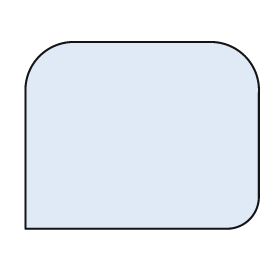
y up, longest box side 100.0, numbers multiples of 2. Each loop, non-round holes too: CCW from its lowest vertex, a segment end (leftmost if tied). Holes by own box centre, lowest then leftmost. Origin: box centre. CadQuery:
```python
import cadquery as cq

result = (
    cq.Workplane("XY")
    .moveTo(-50.0, -40.0)
    .lineTo(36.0, -40.0)
    .threePointArc((46.0, -36.0), (50.0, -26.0))
    .lineTo(50.0, 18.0)
    .threePointArc((44.0, 34.0), (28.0, 40.0))
    .lineTo(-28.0, 40.0)
    .threePointArc((-44.0, 34.0), (-50.0, 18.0))
    .close()
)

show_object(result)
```